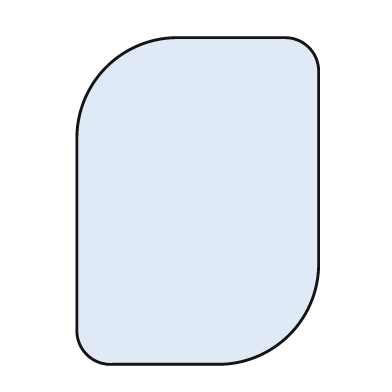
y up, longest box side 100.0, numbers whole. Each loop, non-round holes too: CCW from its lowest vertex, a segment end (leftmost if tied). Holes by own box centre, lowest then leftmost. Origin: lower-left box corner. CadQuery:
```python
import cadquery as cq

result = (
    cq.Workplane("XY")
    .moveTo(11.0, 0.0)
    .lineTo(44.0, 0.0)
    .threePointArc((65.0, 9.0), (74.0, 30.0))
    .lineTo(74.0, 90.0)
    .threePointArc((71.0, 97.0), (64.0, 100.0))
    .lineTo(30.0, 100.0)
    .threePointArc((9.0, 91.0), (0.0, 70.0))
    .lineTo(0.0, 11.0)
    .threePointArc((3.0, 3.0), (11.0, 0.0))
    .close()
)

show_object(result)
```